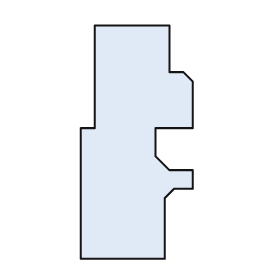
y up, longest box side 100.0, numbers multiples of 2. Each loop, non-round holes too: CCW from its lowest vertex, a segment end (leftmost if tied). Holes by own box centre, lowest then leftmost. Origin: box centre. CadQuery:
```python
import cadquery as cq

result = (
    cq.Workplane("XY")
    .moveTo(-24.0, -50.0)
    .lineTo(12.0, -50.0)
    .lineTo(12.0, -24.0)
    .lineTo(16.0, -20.0)
    .lineTo(24.0, -20.0)
    .lineTo(24.0, -12.0)
    .lineTo(14.0, -12.0)
    .lineTo(8.0, -6.0)
    .lineTo(8.0, 6.0)
    .lineTo(24.0, 6.0)
    .lineTo(24.0, 26.0)
    .lineTo(20.0, 30.0)
    .lineTo(14.0, 30.0)
    .lineTo(14.0, 50.0)
    .lineTo(-18.0, 50.0)
    .lineTo(-18.0, 6.0)
    .lineTo(-24.0, 6.0)
    .close()
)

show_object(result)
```